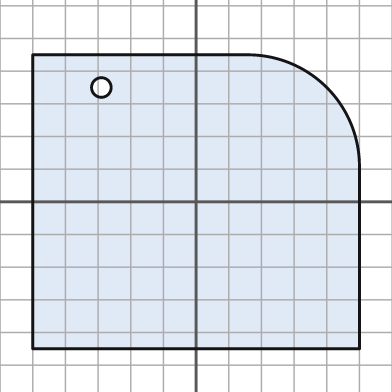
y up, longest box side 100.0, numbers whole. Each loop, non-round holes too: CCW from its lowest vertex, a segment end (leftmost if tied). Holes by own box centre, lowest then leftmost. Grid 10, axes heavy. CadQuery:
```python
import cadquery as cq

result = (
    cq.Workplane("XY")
    .moveTo(-50.0, -45.0)
    .lineTo(50.0, -45.0)
    .lineTo(50.0, 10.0)
    .threePointArc((40.0, 35.0), (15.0, 45.0))
    .lineTo(-50.0, 45.0)
    .close()
    .moveTo(-29.0, 35.0)
    .circle(3.0)
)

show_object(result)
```